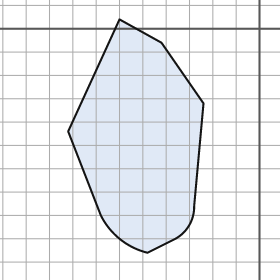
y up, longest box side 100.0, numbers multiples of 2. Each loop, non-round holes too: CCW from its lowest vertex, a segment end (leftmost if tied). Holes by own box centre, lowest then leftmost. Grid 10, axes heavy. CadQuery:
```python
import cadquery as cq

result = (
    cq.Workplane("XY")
    .moveTo(-48.0, -96.0)
    .lineTo(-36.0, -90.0)
    .threePointArc((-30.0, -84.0), (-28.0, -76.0))
    .lineTo(-24.0, -32.0)
    .lineTo(-42.0, -6.0)
    .lineTo(-60.0, 4.0)
    .lineTo(-82.0, -44.0)
    .lineTo(-68.0, -80.0)
    .threePointArc((-60.0, -90.0), (-48.0, -96.0))
    .close()
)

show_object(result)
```